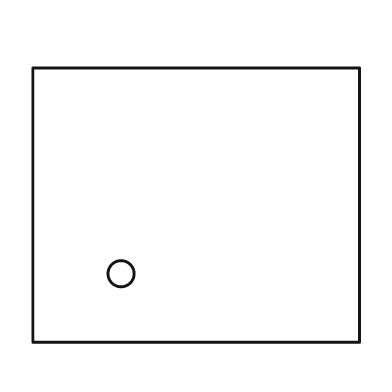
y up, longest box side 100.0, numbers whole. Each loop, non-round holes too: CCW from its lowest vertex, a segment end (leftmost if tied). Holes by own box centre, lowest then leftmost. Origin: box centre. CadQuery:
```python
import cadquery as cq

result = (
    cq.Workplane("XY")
    .moveTo(-50.0, -42.0)
    .lineTo(50.0, -42.0)
    .lineTo(50.0, 42.0)
    .lineTo(-50.0, 42.0)
    .close()
    .moveTo(-23.0, -21.0)
    .circle(4.0)
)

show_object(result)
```